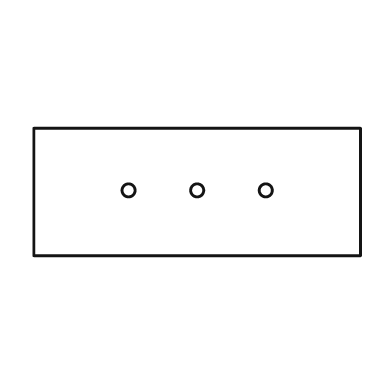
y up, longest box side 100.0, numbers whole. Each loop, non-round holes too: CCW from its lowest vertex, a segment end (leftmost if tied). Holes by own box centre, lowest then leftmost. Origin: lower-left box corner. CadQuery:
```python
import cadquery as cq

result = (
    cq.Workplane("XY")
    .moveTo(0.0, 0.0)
    .lineTo(100.0, 0.0)
    .lineTo(100.0, 39.0)
    .lineTo(0.0, 39.0)
    .close()
    .moveTo(29.0, 20.0)
    .circle(2.0)
    .moveTo(50.0, 20.0)
    .circle(2.0)
    .moveTo(71.0, 20.0)
    .circle(2.0)
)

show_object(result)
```